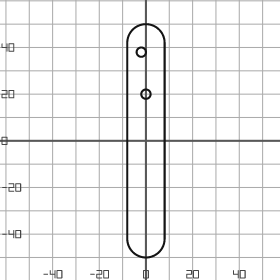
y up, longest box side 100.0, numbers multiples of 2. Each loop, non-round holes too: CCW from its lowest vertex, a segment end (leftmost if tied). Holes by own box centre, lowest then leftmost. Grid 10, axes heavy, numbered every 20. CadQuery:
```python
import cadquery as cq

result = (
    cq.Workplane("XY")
    .moveTo(-8.0, -42.0)
    .threePointArc((0.0, -50.0), (8.0, -42.0))
    .lineTo(8.0, 42.0)
    .threePointArc((0.0, 50.0), (-8.0, 42.0))
    .close()
    .moveTo(0.0, 20.0)
    .circle(2.0)
    .moveTo(-2.0, 38.0)
    .circle(2.0)
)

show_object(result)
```